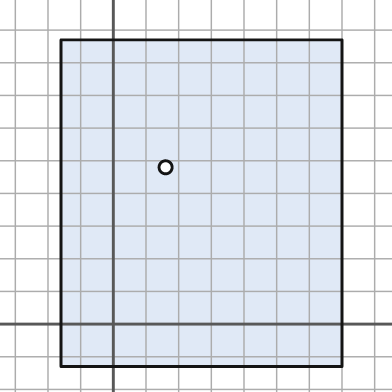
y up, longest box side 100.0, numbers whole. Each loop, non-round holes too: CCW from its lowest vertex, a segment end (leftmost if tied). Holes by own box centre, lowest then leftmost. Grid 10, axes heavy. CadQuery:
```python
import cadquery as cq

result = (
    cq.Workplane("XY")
    .moveTo(-16.0, -13.0)
    .lineTo(70.0, -13.0)
    .lineTo(70.0, 87.0)
    .lineTo(-16.0, 87.0)
    .close()
    .moveTo(16.0, 48.0)
    .circle(2.0)
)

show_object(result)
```